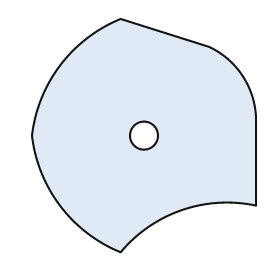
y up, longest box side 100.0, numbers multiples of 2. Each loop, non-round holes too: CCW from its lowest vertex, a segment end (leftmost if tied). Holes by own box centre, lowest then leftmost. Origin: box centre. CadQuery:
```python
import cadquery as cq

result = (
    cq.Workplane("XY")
    .moveTo(-10.0, -50.0)
    .threePointArc((16.0, -32.0), (48.0, -30.0))
    .lineTo(48.0, 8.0)
    .threePointArc((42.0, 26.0), (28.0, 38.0))
    .lineTo(-10.0, 50.0)
    .threePointArc((-36.0, 30.0), (-48.0, 0.0))
    .threePointArc((-36.0, -30.0), (-10.0, -50.0))
    .close()
    .moveTo(0.0, 0.0)
    .circle(6.0)
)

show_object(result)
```